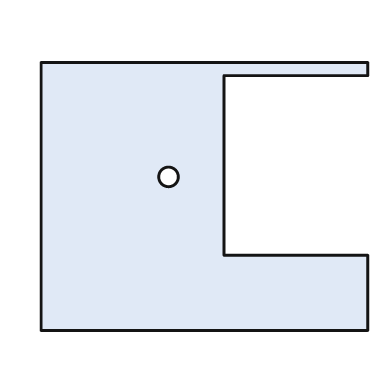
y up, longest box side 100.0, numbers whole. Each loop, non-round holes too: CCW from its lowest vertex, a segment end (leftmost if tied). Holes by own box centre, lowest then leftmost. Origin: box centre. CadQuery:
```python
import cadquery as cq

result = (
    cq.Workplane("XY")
    .moveTo(-50.0, -41.0)
    .lineTo(50.0, -41.0)
    .lineTo(50.0, -18.0)
    .lineTo(6.0, -18.0)
    .lineTo(6.0, 37.0)
    .lineTo(50.0, 37.0)
    .lineTo(50.0, 41.0)
    .lineTo(-50.0, 41.0)
    .close()
    .moveTo(-11.0, 6.0)
    .circle(3.0)
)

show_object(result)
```